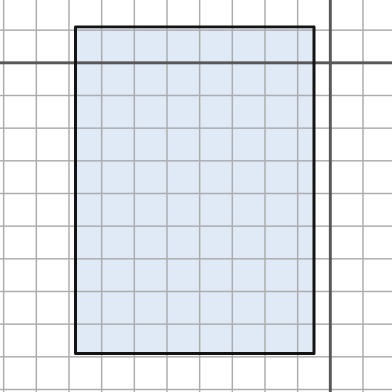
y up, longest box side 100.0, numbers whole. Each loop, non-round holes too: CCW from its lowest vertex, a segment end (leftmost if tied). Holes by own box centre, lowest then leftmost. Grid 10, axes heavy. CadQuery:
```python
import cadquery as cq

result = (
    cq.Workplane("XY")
    .moveTo(-78.0, -89.0)
    .lineTo(-5.0, -89.0)
    .lineTo(-5.0, 11.0)
    .lineTo(-78.0, 11.0)
    .close()
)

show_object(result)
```